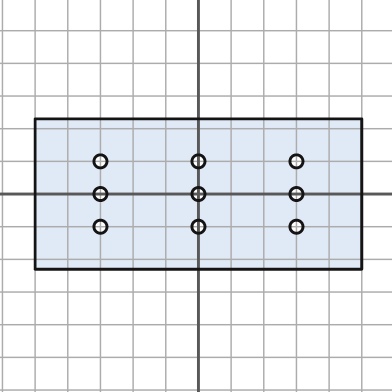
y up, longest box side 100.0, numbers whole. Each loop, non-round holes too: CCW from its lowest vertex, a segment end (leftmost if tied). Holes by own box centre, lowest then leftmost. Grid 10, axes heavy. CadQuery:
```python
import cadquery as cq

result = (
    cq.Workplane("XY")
    .moveTo(-50.0, -23.0)
    .lineTo(50.0, -23.0)
    .lineTo(50.0, 23.0)
    .lineTo(-50.0, 23.0)
    .close()
    .moveTo(-30.0, -10.0)
    .circle(2.0)
    .moveTo(0.0, -10.0)
    .circle(2.0)
    .moveTo(30.0, -10.0)
    .circle(2.0)
    .moveTo(-30.0, 0.0)
    .circle(2.0)
    .moveTo(0.0, 0.0)
    .circle(2.0)
    .moveTo(30.0, 0.0)
    .circle(2.0)
    .moveTo(-30.0, 10.0)
    .circle(2.0)
    .moveTo(0.0, 10.0)
    .circle(2.0)
    .moveTo(30.0, 10.0)
    .circle(2.0)
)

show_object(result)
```